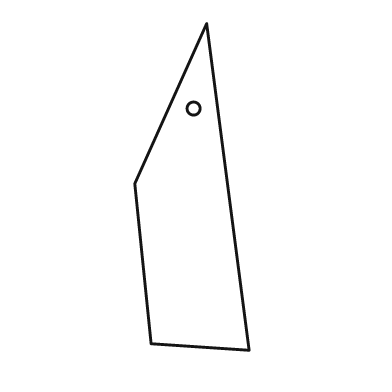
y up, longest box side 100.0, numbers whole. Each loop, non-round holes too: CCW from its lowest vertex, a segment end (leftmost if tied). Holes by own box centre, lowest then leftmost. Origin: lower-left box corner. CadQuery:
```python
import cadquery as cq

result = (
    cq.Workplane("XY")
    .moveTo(35.0, 0.0)
    .lineTo(22.0, 100.0)
    .lineTo(0.0, 51.0)
    .lineTo(5.0, 2.0)
    .close()
    .moveTo(18.0, 74.0)
    .circle(2.0)
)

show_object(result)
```